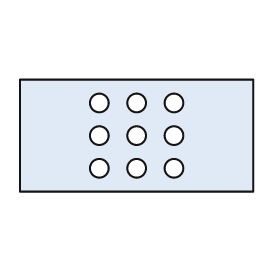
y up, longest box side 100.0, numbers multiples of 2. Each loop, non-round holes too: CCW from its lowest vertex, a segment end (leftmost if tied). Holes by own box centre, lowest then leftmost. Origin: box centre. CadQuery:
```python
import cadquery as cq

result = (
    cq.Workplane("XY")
    .moveTo(-50.0, -24.0)
    .lineTo(50.0, -24.0)
    .lineTo(50.0, 24.0)
    .lineTo(-50.0, 24.0)
    .close()
    .moveTo(-16.0, -14.0)
    .circle(4.0)
    .moveTo(0.0, -14.0)
    .circle(4.0)
    .moveTo(16.0, -14.0)
    .circle(4.0)
    .moveTo(-16.0, 0.0)
    .circle(4.0)
    .moveTo(0.0, 0.0)
    .circle(4.0)
    .moveTo(16.0, 0.0)
    .circle(4.0)
    .moveTo(-16.0, 14.0)
    .circle(4.0)
    .moveTo(0.0, 14.0)
    .circle(4.0)
    .moveTo(16.0, 14.0)
    .circle(4.0)
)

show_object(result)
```